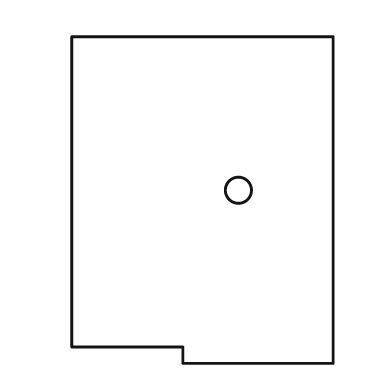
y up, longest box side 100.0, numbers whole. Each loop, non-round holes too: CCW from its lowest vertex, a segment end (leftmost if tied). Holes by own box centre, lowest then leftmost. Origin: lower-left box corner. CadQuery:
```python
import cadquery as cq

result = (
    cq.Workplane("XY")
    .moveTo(34.0, 0.0)
    .lineTo(80.0, 0.0)
    .lineTo(80.0, 100.0)
    .lineTo(0.0, 100.0)
    .lineTo(0.0, 5.0)
    .lineTo(34.0, 5.0)
    .close()
    .moveTo(51.0, 53.0)
    .circle(4.0)
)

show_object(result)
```